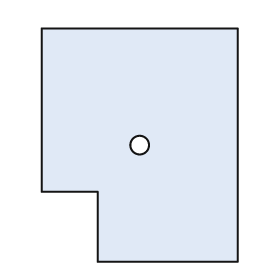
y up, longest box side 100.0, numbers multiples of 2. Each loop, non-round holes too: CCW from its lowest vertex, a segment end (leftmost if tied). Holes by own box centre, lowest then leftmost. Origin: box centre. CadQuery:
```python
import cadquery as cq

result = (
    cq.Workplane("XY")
    .moveTo(-18.0, -50.0)
    .lineTo(42.0, -50.0)
    .lineTo(42.0, 50.0)
    .lineTo(-42.0, 50.0)
    .lineTo(-42.0, -20.0)
    .lineTo(-18.0, -20.0)
    .close()
    .moveTo(0.0, 0.0)
    .circle(4.0)
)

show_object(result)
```